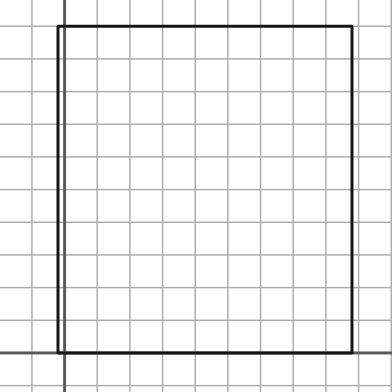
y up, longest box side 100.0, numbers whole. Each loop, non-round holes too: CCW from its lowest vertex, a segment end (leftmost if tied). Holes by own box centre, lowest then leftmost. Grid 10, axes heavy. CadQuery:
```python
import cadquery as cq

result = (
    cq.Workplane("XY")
    .moveTo(-2.0, 0.0)
    .lineTo(88.0, 0.0)
    .lineTo(88.0, 100.0)
    .lineTo(-2.0, 100.0)
    .close()
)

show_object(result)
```